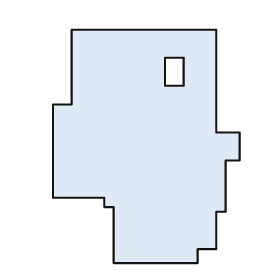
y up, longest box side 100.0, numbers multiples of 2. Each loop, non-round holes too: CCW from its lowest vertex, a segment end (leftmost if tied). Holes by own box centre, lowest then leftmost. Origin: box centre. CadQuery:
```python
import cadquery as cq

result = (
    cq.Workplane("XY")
    .moveTo(-14.0, -50.0)
    .lineTo(22.0, -50.0)
    .lineTo(22.0, -44.0)
    .lineTo(30.0, -44.0)
    .lineTo(30.0, -28.0)
    .lineTo(34.0, -28.0)
    .lineTo(34.0, -6.0)
    .lineTo(40.0, -6.0)
    .lineTo(40.0, 6.0)
    .lineTo(30.0, 6.0)
    .lineTo(30.0, 50.0)
    .lineTo(-32.0, 50.0)
    .lineTo(-32.0, 18.0)
    .lineTo(-40.0, 18.0)
    .lineTo(-40.0, -22.0)
    .lineTo(-18.0, -22.0)
    .lineTo(-18.0, -26.0)
    .lineTo(-14.0, -26.0)
    .close()
    .moveTo(8.0, 26.0)
    .lineTo(16.0, 26.0)
    .lineTo(16.0, 38.0)
    .lineTo(8.0, 38.0)
    .close()
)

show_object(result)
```